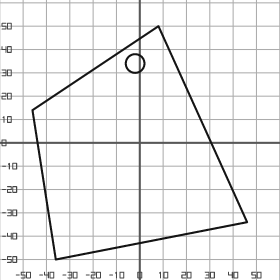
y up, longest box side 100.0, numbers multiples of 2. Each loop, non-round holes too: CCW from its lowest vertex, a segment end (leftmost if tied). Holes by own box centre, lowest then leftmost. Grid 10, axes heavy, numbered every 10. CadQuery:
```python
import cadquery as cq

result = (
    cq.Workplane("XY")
    .moveTo(-36.0, -50.0)
    .lineTo(46.0, -34.0)
    .lineTo(8.0, 50.0)
    .lineTo(-46.0, 14.0)
    .close()
    .moveTo(-2.0, 34.0)
    .circle(4.0)
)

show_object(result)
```